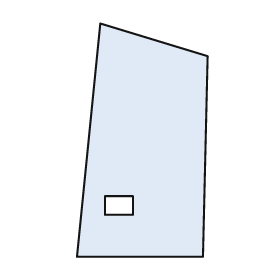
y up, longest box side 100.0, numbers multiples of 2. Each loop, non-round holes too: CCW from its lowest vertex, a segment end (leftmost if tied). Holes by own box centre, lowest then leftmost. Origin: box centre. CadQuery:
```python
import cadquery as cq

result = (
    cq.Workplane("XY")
    .moveTo(-28.0, -50.0)
    .lineTo(26.0, -50.0)
    .lineTo(28.0, 36.0)
    .lineTo(-18.0, 50.0)
    .close()
    .moveTo(-16.0, -32.0)
    .lineTo(-4.0, -32.0)
    .lineTo(-4.0, -24.0)
    .lineTo(-16.0, -24.0)
    .close()
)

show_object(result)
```